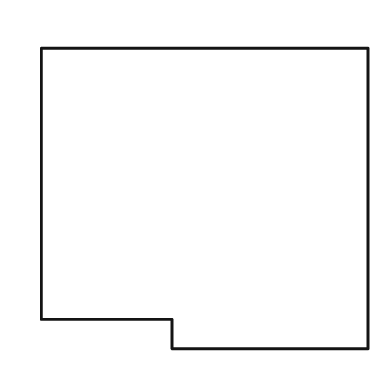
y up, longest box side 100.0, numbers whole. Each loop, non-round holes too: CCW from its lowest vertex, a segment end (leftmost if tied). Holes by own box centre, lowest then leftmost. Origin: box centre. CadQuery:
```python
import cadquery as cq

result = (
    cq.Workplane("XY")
    .moveTo(-10.0, -46.0)
    .lineTo(50.0, -46.0)
    .lineTo(50.0, 46.0)
    .lineTo(-50.0, 46.0)
    .lineTo(-50.0, -37.0)
    .lineTo(-10.0, -37.0)
    .close()
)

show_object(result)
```